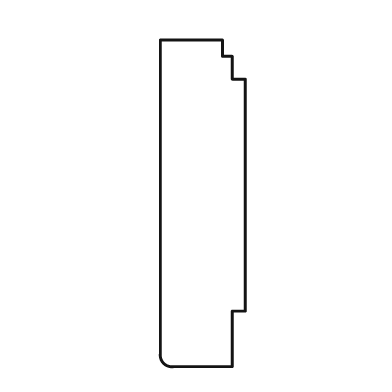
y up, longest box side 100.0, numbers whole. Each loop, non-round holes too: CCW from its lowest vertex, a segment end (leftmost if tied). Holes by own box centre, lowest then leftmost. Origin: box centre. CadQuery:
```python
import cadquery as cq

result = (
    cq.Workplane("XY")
    .moveTo(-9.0, -50.0)
    .lineTo(9.0, -50.0)
    .lineTo(9.0, -33.0)
    .lineTo(13.0, -33.0)
    .lineTo(13.0, 38.0)
    .lineTo(9.0, 38.0)
    .lineTo(9.0, 45.0)
    .lineTo(6.0, 45.0)
    .lineTo(6.0, 50.0)
    .lineTo(-13.0, 50.0)
    .lineTo(-13.0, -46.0)
    .threePointArc((-12.0, -49.0), (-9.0, -50.0))
    .close()
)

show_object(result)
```